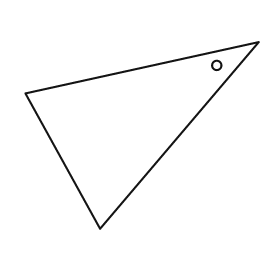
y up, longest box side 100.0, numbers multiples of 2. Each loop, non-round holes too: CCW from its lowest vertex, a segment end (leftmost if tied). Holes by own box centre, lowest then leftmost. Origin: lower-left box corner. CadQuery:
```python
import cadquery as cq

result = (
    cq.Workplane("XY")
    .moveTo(32.0, 0.0)
    .lineTo(100.0, 80.0)
    .lineTo(0.0, 58.0)
    .close()
    .moveTo(82.0, 70.0)
    .circle(2.0)
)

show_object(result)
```